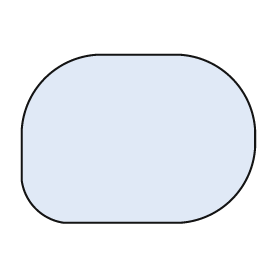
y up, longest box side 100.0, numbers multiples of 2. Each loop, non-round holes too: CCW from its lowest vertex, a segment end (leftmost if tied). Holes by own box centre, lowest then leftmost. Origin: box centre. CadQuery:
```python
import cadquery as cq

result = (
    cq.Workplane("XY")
    .moveTo(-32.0, -36.0)
    .lineTo(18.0, -36.0)
    .threePointArc((40.0, -26.0), (50.0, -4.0))
    .lineTo(50.0, 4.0)
    .threePointArc((40.0, 26.0), (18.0, 36.0))
    .lineTo(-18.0, 36.0)
    .threePointArc((-40.0, 26.0), (-50.0, 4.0))
    .lineTo(-50.0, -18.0)
    .threePointArc((-44.0, -30.0), (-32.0, -36.0))
    .close()
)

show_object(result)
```